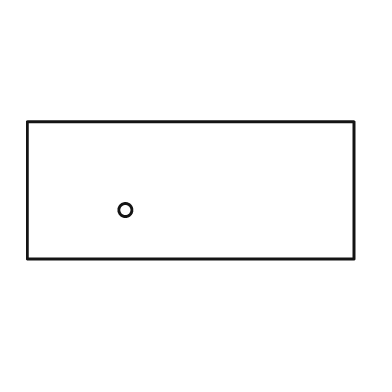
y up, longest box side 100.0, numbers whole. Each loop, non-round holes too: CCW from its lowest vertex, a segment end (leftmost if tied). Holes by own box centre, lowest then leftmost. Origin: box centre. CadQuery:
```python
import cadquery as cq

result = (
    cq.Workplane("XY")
    .moveTo(-50.0, -21.0)
    .lineTo(50.0, -21.0)
    .lineTo(50.0, 21.0)
    .lineTo(-50.0, 21.0)
    .close()
    .moveTo(-20.0, -6.0)
    .circle(2.0)
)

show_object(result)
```